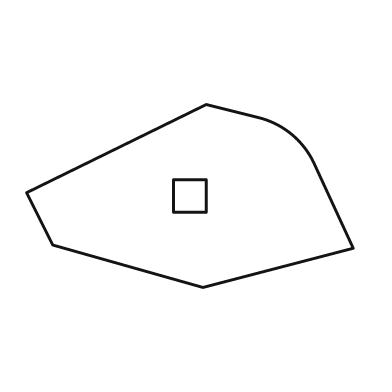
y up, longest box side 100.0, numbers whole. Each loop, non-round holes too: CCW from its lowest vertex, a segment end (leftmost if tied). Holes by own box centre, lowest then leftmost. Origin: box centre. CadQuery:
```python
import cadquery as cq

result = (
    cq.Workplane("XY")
    .moveTo(4.0, -28.0)
    .lineTo(50.0, -16.0)
    .lineTo(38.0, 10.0)
    .threePointArc((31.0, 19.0), (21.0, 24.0))
    .lineTo(5.0, 28.0)
    .lineTo(-50.0, 1.0)
    .lineTo(-42.0, -15.0)
    .close()
    .moveTo(-5.0, -5.0)
    .lineTo(5.0, -5.0)
    .lineTo(5.0, 5.0)
    .lineTo(-5.0, 5.0)
    .close()
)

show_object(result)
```